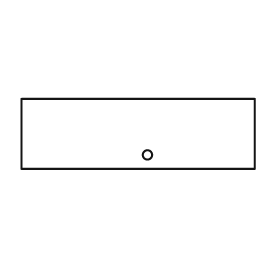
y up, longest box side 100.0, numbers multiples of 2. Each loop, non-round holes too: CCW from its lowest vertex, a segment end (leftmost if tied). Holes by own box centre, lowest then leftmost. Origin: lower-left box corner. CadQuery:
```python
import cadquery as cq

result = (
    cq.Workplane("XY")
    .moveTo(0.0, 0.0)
    .lineTo(100.0, 0.0)
    .lineTo(100.0, 30.0)
    .lineTo(0.0, 30.0)
    .close()
    .moveTo(54.0, 6.0)
    .circle(2.0)
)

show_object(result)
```